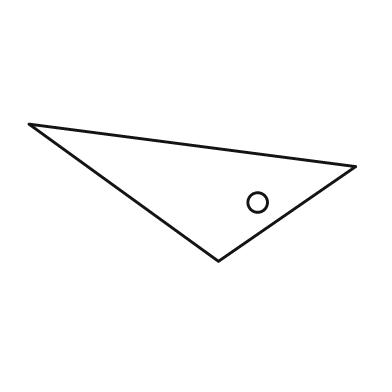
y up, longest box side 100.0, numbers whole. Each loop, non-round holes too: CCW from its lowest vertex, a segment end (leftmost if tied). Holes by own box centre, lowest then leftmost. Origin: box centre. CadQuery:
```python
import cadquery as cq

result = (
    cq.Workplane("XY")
    .moveTo(8.0, -21.0)
    .lineTo(50.0, 8.0)
    .lineTo(-50.0, 21.0)
    .close()
    .moveTo(20.0, -3.0)
    .circle(3.0)
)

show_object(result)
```